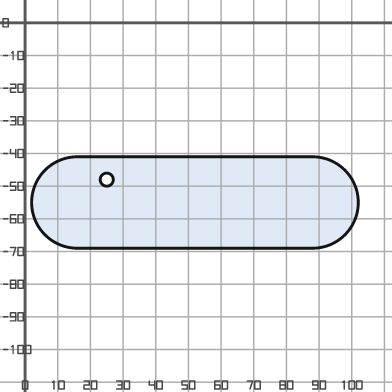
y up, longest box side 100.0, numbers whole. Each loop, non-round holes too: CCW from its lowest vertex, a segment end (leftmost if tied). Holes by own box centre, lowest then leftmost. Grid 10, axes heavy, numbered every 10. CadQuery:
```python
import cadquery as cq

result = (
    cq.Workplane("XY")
    .moveTo(16.0, -69.0)
    .lineTo(88.0, -69.0)
    .threePointArc((102.0, -55.0), (88.0, -41.0))
    .lineTo(16.0, -41.0)
    .threePointArc((2.0, -55.0), (16.0, -69.0))
    .close()
    .moveTo(25.0, -48.0)
    .circle(2.0)
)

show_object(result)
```